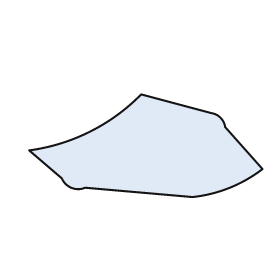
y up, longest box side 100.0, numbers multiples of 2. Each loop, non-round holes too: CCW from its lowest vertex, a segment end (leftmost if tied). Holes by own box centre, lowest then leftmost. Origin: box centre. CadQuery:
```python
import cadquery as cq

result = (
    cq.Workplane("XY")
    .moveTo(20.0, -22.0)
    .threePointArc((36.0, -18.0), (50.0, -10.0))
    .lineTo(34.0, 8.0)
    .threePointArc((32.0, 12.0), (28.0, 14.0))
    .lineTo(-2.0, 22.0)
    .threePointArc((-24.0, 6.0), (-50.0, -2.0))
    .lineTo(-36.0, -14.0)
    .threePointArc((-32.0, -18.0), (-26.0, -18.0))
    .close()
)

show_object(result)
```